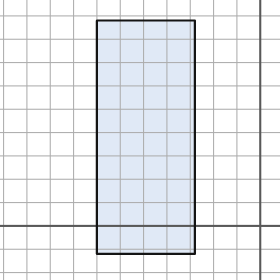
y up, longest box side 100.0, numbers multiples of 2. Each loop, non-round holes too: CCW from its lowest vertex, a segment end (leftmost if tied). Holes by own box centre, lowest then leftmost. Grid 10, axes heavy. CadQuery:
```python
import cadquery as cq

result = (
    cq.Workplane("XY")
    .moveTo(-70.0, -12.0)
    .lineTo(-28.0, -12.0)
    .lineTo(-28.0, 88.0)
    .lineTo(-70.0, 88.0)
    .close()
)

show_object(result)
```